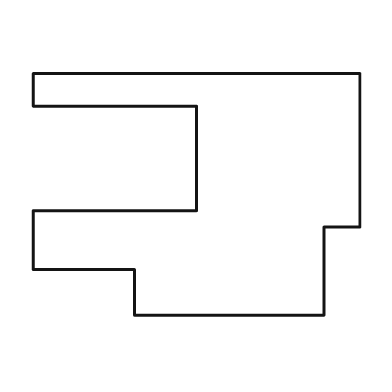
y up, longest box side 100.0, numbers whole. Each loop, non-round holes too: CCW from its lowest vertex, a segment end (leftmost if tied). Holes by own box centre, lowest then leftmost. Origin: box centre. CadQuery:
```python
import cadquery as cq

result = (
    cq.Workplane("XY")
    .moveTo(-19.0, -37.0)
    .lineTo(39.0, -37.0)
    .lineTo(39.0, -10.0)
    .lineTo(50.0, -10.0)
    .lineTo(50.0, 37.0)
    .lineTo(-50.0, 37.0)
    .lineTo(-50.0, 27.0)
    .lineTo(0.0, 27.0)
    .lineTo(0.0, -5.0)
    .lineTo(-50.0, -5.0)
    .lineTo(-50.0, -23.0)
    .lineTo(-19.0, -23.0)
    .close()
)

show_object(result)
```